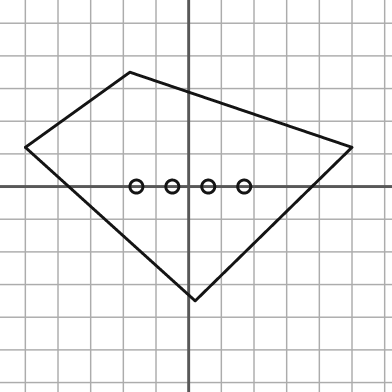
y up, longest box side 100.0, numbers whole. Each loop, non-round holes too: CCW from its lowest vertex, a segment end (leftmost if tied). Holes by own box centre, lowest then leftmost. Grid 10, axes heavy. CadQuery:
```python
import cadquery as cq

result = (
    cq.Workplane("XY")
    .moveTo(2.0, -35.0)
    .lineTo(50.0, 12.0)
    .lineTo(-18.0, 35.0)
    .lineTo(-50.0, 12.0)
    .close()
    .moveTo(-16.0, 0.0)
    .circle(2.0)
    .moveTo(-5.0, 0.0)
    .circle(2.0)
    .moveTo(6.0, 0.0)
    .circle(2.0)
    .moveTo(17.0, 0.0)
    .circle(2.0)
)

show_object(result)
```